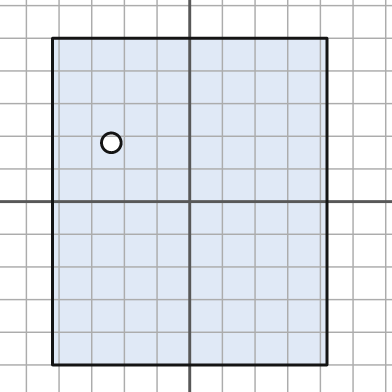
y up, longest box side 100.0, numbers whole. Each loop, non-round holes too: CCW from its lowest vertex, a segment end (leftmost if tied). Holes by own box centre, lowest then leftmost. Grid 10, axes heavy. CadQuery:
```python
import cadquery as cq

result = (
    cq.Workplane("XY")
    .moveTo(-42.0, -50.0)
    .lineTo(42.0, -50.0)
    .lineTo(42.0, 50.0)
    .lineTo(-42.0, 50.0)
    .close()
    .moveTo(-24.0, 18.0)
    .circle(3.0)
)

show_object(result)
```